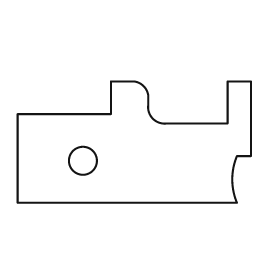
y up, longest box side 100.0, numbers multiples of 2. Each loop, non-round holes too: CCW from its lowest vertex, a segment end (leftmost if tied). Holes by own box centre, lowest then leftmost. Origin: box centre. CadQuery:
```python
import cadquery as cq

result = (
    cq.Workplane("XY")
    .moveTo(-50.0, -26.0)
    .lineTo(44.0, -26.0)
    .threePointArc((42.0, -16.0), (44.0, -6.0))
    .lineTo(50.0, -6.0)
    .lineTo(50.0, 26.0)
    .lineTo(40.0, 26.0)
    .lineTo(40.0, 8.0)
    .lineTo(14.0, 8.0)
    .threePointArc((8.0, 10.0), (6.0, 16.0))
    .lineTo(6.0, 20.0)
    .threePointArc((4.0, 24.0), (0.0, 26.0))
    .lineTo(-10.0, 26.0)
    .lineTo(-10.0, 12.0)
    .lineTo(-50.0, 12.0)
    .close()
    .moveTo(-22.0, -8.0)
    .circle(6.0)
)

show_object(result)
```